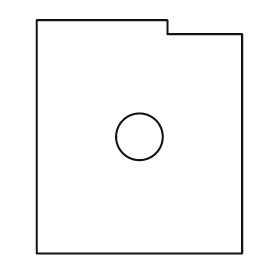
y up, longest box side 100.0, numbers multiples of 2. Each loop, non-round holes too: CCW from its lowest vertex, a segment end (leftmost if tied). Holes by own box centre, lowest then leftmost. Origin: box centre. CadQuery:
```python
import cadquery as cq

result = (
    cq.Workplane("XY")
    .moveTo(-44.0, -50.0)
    .lineTo(44.0, -50.0)
    .lineTo(44.0, 44.0)
    .lineTo(12.0, 44.0)
    .lineTo(12.0, 50.0)
    .lineTo(-44.0, 50.0)
    .close()
    .moveTo(0.0, 0.0)
    .circle(10.0)
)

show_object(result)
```